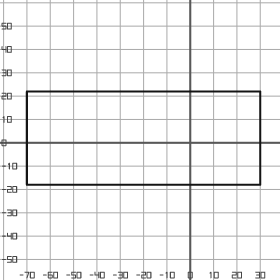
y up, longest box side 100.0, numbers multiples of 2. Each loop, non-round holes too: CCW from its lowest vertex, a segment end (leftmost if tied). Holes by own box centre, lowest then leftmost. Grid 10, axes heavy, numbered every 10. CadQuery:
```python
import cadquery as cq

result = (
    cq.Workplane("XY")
    .moveTo(-70.0, -18.0)
    .lineTo(30.0, -18.0)
    .lineTo(30.0, 22.0)
    .lineTo(-70.0, 22.0)
    .close()
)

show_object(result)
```